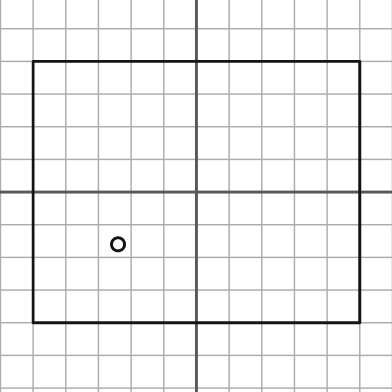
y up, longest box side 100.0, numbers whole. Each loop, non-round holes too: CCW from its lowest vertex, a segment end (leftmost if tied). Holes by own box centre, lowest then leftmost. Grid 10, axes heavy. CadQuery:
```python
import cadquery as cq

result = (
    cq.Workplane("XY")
    .moveTo(-50.0, -40.0)
    .lineTo(50.0, -40.0)
    .lineTo(50.0, 40.0)
    .lineTo(-50.0, 40.0)
    .close()
    .moveTo(-24.0, -16.0)
    .circle(2.0)
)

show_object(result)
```